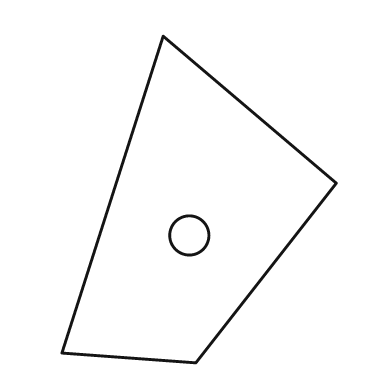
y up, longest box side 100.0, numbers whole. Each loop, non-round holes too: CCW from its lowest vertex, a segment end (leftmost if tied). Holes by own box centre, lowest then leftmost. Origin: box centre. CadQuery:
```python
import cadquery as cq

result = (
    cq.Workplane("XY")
    .moveTo(-1.0, -50.0)
    .lineTo(42.0, 5.0)
    .lineTo(-11.0, 50.0)
    .lineTo(-42.0, -47.0)
    .close()
    .moveTo(-3.0, -11.0)
    .circle(6.0)
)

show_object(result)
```